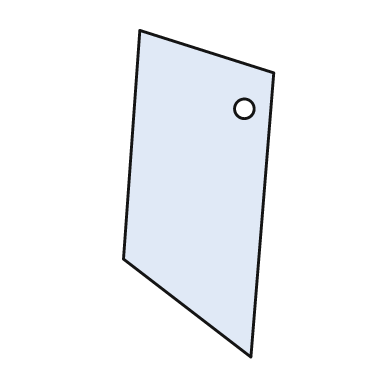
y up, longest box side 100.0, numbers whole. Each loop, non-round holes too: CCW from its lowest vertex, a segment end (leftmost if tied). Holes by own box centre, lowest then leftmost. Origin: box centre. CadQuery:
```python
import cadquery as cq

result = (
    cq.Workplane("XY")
    .moveTo(16.0, -50.0)
    .lineTo(23.0, 37.0)
    .lineTo(-18.0, 50.0)
    .lineTo(-23.0, -20.0)
    .close()
    .moveTo(14.0, 26.0)
    .circle(3.0)
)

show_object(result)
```